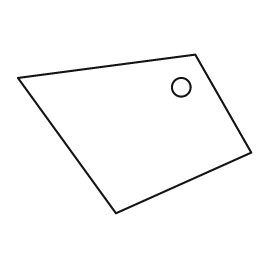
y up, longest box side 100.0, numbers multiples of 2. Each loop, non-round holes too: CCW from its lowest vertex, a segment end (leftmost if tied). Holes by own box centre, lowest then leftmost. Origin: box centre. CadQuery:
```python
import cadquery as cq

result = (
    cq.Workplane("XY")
    .moveTo(-8.0, -34.0)
    .lineTo(50.0, -8.0)
    .lineTo(26.0, 34.0)
    .lineTo(-50.0, 24.0)
    .close()
    .moveTo(20.0, 20.0)
    .circle(4.0)
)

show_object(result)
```